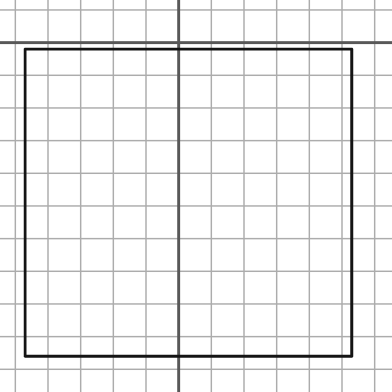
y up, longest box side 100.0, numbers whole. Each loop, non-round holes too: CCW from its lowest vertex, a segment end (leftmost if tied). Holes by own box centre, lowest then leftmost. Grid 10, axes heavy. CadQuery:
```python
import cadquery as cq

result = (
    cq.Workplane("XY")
    .moveTo(-47.0, -96.0)
    .lineTo(53.0, -96.0)
    .lineTo(53.0, -2.0)
    .lineTo(-47.0, -2.0)
    .close()
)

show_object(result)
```